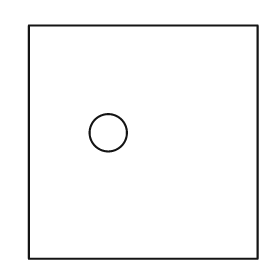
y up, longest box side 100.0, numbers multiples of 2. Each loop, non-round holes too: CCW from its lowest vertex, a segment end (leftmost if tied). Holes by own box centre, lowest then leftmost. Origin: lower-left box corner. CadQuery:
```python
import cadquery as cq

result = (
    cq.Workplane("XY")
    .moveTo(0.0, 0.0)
    .lineTo(98.0, 0.0)
    .lineTo(98.0, 100.0)
    .lineTo(0.0, 100.0)
    .close()
    .moveTo(34.0, 54.0)
    .circle(8.0)
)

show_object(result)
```